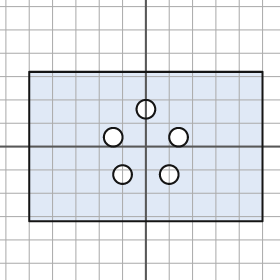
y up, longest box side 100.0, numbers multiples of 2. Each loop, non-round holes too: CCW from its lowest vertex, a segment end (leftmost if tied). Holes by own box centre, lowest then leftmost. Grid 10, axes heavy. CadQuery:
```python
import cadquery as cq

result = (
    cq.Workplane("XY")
    .moveTo(-50.0, -32.0)
    .lineTo(50.0, -32.0)
    .lineTo(50.0, 32.0)
    .lineTo(-50.0, 32.0)
    .close()
    .moveTo(-10.0, -12.0)
    .circle(4.0)
    .moveTo(10.0, -12.0)
    .circle(4.0)
    .moveTo(-14.0, 4.0)
    .circle(4.0)
    .moveTo(14.0, 4.0)
    .circle(4.0)
    .moveTo(0.0, 16.0)
    .circle(4.0)
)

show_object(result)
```